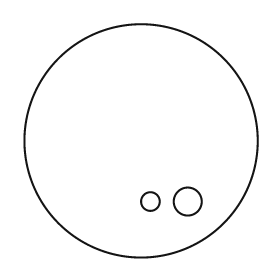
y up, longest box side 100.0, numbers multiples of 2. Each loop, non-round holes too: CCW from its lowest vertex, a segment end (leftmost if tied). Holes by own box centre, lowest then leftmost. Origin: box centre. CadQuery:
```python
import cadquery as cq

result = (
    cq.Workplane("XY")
    .moveTo(0.0, 0.0)
    .circle(50.0)
    .moveTo(4.0, -26.0)
    .circle(4.0)
    .moveTo(20.0, -26.0)
    .circle(6.0)
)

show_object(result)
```